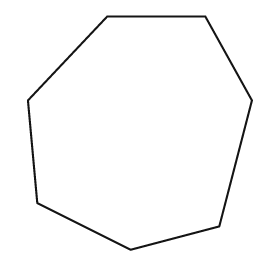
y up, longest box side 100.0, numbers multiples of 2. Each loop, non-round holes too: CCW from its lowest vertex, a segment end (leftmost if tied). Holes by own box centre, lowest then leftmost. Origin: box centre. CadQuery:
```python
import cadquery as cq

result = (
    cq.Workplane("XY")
    .moveTo(-4.0, -50.0)
    .lineTo(34.0, -40.0)
    .lineTo(48.0, 14.0)
    .lineTo(28.0, 50.0)
    .lineTo(-14.0, 50.0)
    .lineTo(-48.0, 14.0)
    .lineTo(-44.0, -30.0)
    .close()
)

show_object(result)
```